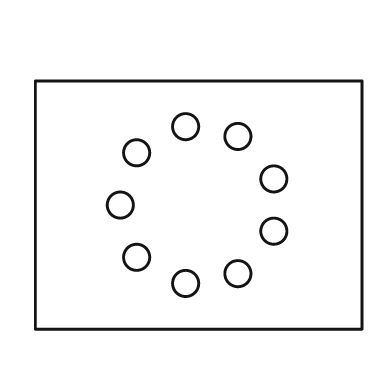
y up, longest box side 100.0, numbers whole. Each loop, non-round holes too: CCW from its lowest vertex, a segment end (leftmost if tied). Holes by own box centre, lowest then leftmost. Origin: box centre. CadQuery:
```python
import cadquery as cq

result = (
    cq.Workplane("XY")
    .moveTo(-50.0, -38.0)
    .lineTo(50.0, -38.0)
    .lineTo(50.0, 38.0)
    .lineTo(-50.0, 38.0)
    .close()
    .moveTo(-4.0, -24.0)
    .circle(4.0)
    .moveTo(12.0, -21.0)
    .circle(4.0)
    .moveTo(-19.0, -16.0)
    .circle(4.0)
    .moveTo(23.0, -8.0)
    .circle(4.0)
    .moveTo(-24.0, 0.0)
    .circle(4.0)
    .moveTo(23.0, 8.0)
    .circle(4.0)
    .moveTo(-19.0, 16.0)
    .circle(4.0)
    .moveTo(12.0, 21.0)
    .circle(4.0)
    .moveTo(-4.0, 24.0)
    .circle(4.0)
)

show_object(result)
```